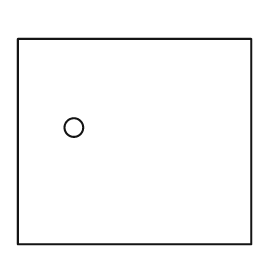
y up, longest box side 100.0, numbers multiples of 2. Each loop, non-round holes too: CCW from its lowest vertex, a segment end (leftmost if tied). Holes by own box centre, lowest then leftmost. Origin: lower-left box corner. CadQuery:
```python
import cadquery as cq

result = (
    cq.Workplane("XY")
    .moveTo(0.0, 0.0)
    .lineTo(100.0, 0.0)
    .lineTo(100.0, 88.0)
    .lineTo(0.0, 88.0)
    .close()
    .moveTo(24.0, 50.0)
    .circle(4.0)
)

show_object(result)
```